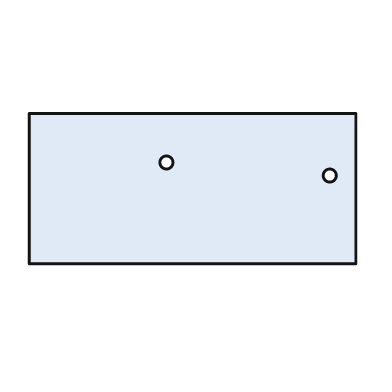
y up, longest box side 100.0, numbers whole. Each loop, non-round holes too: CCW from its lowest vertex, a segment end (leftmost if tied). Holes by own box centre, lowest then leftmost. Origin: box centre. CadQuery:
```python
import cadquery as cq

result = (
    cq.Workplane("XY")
    .moveTo(-50.0, -23.0)
    .lineTo(50.0, -23.0)
    .lineTo(50.0, 23.0)
    .lineTo(-50.0, 23.0)
    .close()
    .moveTo(42.0, 4.0)
    .circle(2.0)
    .moveTo(-8.0, 8.0)
    .circle(2.0)
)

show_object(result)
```